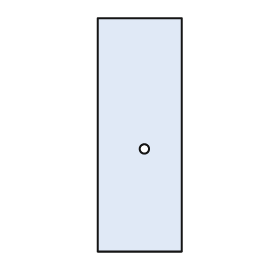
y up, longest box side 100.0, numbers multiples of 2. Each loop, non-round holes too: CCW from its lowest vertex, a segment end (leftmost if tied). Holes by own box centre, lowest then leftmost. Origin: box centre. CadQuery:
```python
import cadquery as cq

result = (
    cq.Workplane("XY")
    .moveTo(-18.0, -50.0)
    .lineTo(18.0, -50.0)
    .lineTo(18.0, 50.0)
    .lineTo(-18.0, 50.0)
    .close()
    .moveTo(2.0, -6.0)
    .circle(2.0)
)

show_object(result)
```